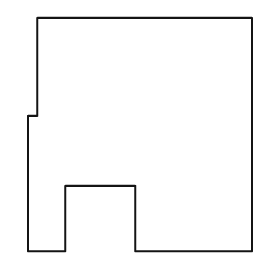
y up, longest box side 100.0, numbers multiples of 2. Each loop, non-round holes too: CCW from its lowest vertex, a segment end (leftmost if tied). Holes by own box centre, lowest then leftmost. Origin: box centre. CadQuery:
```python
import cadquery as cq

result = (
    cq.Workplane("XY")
    .moveTo(-48.0, -50.0)
    .lineTo(-32.0, -50.0)
    .lineTo(-32.0, -22.0)
    .lineTo(-2.0, -22.0)
    .lineTo(-2.0, -50.0)
    .lineTo(48.0, -50.0)
    .lineTo(48.0, 50.0)
    .lineTo(-44.0, 50.0)
    .lineTo(-44.0, 8.0)
    .lineTo(-48.0, 8.0)
    .close()
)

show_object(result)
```